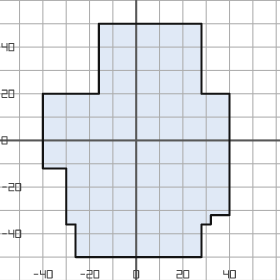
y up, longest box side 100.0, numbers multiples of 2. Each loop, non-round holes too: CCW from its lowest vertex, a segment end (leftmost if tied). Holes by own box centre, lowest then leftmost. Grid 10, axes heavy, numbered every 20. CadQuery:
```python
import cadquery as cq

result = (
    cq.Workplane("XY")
    .moveTo(-26.0, -50.0)
    .lineTo(28.0, -50.0)
    .lineTo(28.0, -36.0)
    .lineTo(32.0, -36.0)
    .lineTo(32.0, -32.0)
    .lineTo(40.0, -32.0)
    .lineTo(40.0, 20.0)
    .lineTo(28.0, 20.0)
    .lineTo(28.0, 50.0)
    .lineTo(-16.0, 50.0)
    .lineTo(-16.0, 20.0)
    .lineTo(-40.0, 20.0)
    .lineTo(-40.0, -12.0)
    .lineTo(-30.0, -12.0)
    .lineTo(-30.0, -36.0)
    .lineTo(-26.0, -36.0)
    .close()
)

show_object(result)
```